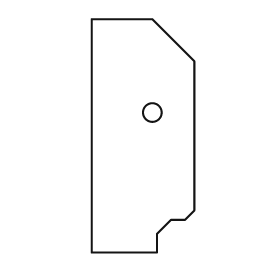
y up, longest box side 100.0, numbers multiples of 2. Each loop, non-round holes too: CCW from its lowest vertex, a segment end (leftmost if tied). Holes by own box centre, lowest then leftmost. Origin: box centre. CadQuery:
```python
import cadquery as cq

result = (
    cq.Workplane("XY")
    .moveTo(-22.0, -50.0)
    .lineTo(6.0, -50.0)
    .lineTo(6.0, -42.0)
    .lineTo(12.0, -36.0)
    .lineTo(18.0, -36.0)
    .lineTo(22.0, -32.0)
    .lineTo(22.0, 32.0)
    .lineTo(4.0, 50.0)
    .lineTo(-22.0, 50.0)
    .close()
    .moveTo(4.0, 10.0)
    .circle(4.0)
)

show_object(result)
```